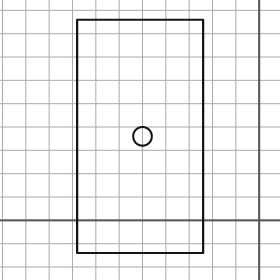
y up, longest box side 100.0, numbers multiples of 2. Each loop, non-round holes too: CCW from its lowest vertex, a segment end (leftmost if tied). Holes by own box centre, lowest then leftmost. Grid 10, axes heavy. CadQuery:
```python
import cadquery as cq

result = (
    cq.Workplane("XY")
    .moveTo(-78.0, -14.0)
    .lineTo(-24.0, -14.0)
    .lineTo(-24.0, 86.0)
    .lineTo(-78.0, 86.0)
    .close()
    .moveTo(-50.0, 36.0)
    .circle(4.0)
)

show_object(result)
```